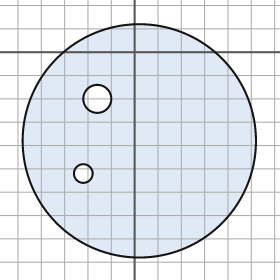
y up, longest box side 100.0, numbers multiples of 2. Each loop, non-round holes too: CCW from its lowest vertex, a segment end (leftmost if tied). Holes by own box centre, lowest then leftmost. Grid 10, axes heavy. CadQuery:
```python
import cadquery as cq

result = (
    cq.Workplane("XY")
    .moveTo(2.0, -38.0)
    .circle(50.0)
    .moveTo(-22.0, -52.0)
    .circle(4.0)
    .moveTo(-16.0, -20.0)
    .circle(6.0)
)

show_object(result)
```